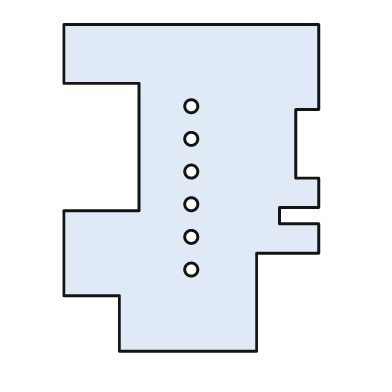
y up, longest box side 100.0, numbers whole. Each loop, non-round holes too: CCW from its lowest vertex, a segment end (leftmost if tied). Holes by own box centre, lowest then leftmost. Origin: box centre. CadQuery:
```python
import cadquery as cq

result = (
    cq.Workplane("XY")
    .moveTo(-22.0, -50.0)
    .lineTo(20.0, -50.0)
    .lineTo(20.0, -20.0)
    .lineTo(39.0, -20.0)
    .lineTo(39.0, -11.0)
    .lineTo(27.0, -11.0)
    .lineTo(27.0, -6.0)
    .lineTo(39.0, -6.0)
    .lineTo(39.0, 3.0)
    .lineTo(32.0, 3.0)
    .lineTo(32.0, 24.0)
    .lineTo(39.0, 24.0)
    .lineTo(39.0, 50.0)
    .lineTo(-39.0, 50.0)
    .lineTo(-39.0, 32.0)
    .lineTo(-16.0, 32.0)
    .lineTo(-16.0, -7.0)
    .lineTo(-39.0, -7.0)
    .lineTo(-39.0, -33.0)
    .lineTo(-22.0, -33.0)
    .close()
    .moveTo(0.0, -25.0)
    .circle(2.0)
    .moveTo(0.0, -15.0)
    .circle(2.0)
    .moveTo(0.0, -5.0)
    .circle(2.0)
    .moveTo(0.0, 5.0)
    .circle(2.0)
    .moveTo(0.0, 15.0)
    .circle(2.0)
    .moveTo(0.0, 25.0)
    .circle(2.0)
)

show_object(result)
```